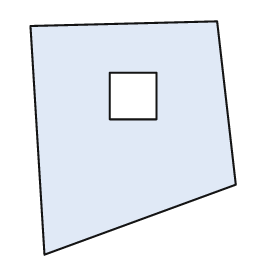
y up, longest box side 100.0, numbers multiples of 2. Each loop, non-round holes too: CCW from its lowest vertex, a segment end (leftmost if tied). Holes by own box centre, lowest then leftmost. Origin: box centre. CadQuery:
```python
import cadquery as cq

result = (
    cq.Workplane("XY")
    .moveTo(-38.0, -50.0)
    .lineTo(44.0, -20.0)
    .lineTo(36.0, 50.0)
    .lineTo(-44.0, 48.0)
    .close()
    .moveTo(-10.0, 8.0)
    .lineTo(10.0, 8.0)
    .lineTo(10.0, 28.0)
    .lineTo(-10.0, 28.0)
    .close()
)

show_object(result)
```